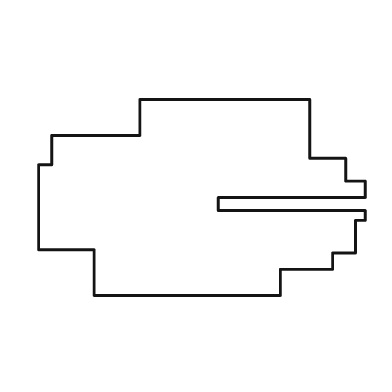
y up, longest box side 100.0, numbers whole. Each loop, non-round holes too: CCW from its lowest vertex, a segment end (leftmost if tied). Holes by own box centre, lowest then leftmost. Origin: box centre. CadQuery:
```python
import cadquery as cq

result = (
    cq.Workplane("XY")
    .moveTo(-33.0, -30.0)
    .lineTo(24.0, -30.0)
    .lineTo(24.0, -22.0)
    .lineTo(40.0, -22.0)
    .lineTo(40.0, -17.0)
    .lineTo(47.0, -17.0)
    .lineTo(47.0, -7.0)
    .lineTo(50.0, -7.0)
    .lineTo(50.0, -4.0)
    .lineTo(5.0, -4.0)
    .lineTo(5.0, 0.0)
    .lineTo(50.0, 0.0)
    .lineTo(50.0, 5.0)
    .lineTo(44.0, 5.0)
    .lineTo(44.0, 12.0)
    .lineTo(33.0, 12.0)
    .lineTo(33.0, 30.0)
    .lineTo(-19.0, 30.0)
    .lineTo(-19.0, 19.0)
    .lineTo(-46.0, 19.0)
    .lineTo(-46.0, 10.0)
    .lineTo(-50.0, 10.0)
    .lineTo(-50.0, -16.0)
    .lineTo(-33.0, -16.0)
    .close()
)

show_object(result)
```